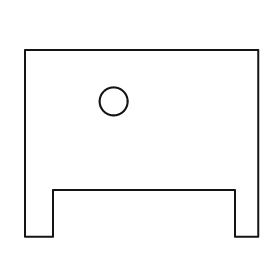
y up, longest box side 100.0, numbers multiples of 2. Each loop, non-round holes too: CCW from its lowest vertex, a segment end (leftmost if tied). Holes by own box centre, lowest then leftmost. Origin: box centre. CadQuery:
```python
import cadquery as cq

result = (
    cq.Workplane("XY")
    .moveTo(-50.0, -40.0)
    .lineTo(-38.0, -40.0)
    .lineTo(-38.0, -20.0)
    .lineTo(40.0, -20.0)
    .lineTo(40.0, -40.0)
    .lineTo(50.0, -40.0)
    .lineTo(50.0, 40.0)
    .lineTo(-50.0, 40.0)
    .close()
    .moveTo(-12.0, 18.0)
    .circle(6.0)
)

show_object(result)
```